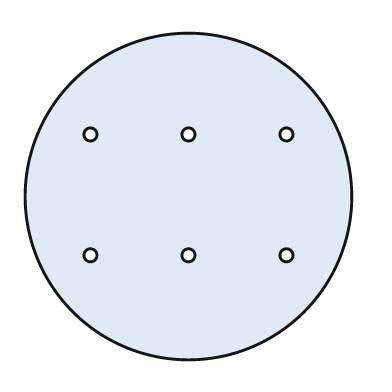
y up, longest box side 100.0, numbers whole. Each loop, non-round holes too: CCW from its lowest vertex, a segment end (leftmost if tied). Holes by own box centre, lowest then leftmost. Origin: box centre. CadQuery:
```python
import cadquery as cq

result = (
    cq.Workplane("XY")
    .moveTo(0.0, 0.0)
    .circle(50.0)
    .moveTo(-30.0, -18.0)
    .circle(2.0)
    .moveTo(0.0, -18.0)
    .circle(2.0)
    .moveTo(30.0, -18.0)
    .circle(2.0)
    .moveTo(-30.0, 19.0)
    .circle(2.0)
    .moveTo(0.0, 19.0)
    .circle(2.0)
    .moveTo(30.0, 19.0)
    .circle(2.0)
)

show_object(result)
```